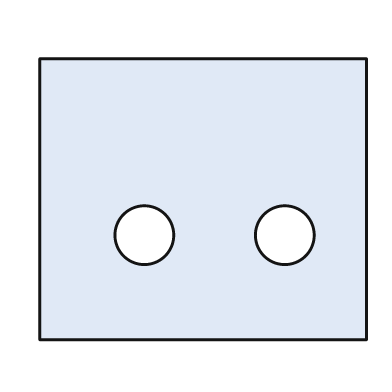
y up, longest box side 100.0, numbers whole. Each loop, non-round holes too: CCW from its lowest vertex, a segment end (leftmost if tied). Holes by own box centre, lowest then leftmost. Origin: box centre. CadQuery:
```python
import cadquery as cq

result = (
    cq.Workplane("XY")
    .moveTo(-50.0, -43.0)
    .lineTo(50.0, -43.0)
    .lineTo(50.0, 43.0)
    .lineTo(-50.0, 43.0)
    .close()
    .moveTo(-18.0, -11.0)
    .circle(9.0)
    .moveTo(25.0, -11.0)
    .circle(9.0)
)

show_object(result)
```